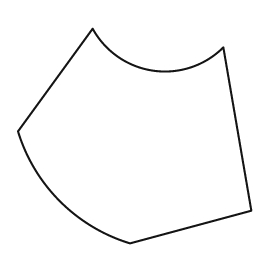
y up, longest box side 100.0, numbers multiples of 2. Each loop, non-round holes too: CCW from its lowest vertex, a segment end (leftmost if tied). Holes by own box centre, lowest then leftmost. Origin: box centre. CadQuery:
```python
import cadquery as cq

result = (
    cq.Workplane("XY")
    .moveTo(-2.0, -46.0)
    .lineTo(50.0, -32.0)
    .lineTo(38.0, 38.0)
    .threePointArc((8.0, 28.0), (-18.0, 46.0))
    .lineTo(-50.0, 2.0)
    .threePointArc((-32.0, -28.0), (-2.0, -46.0))
    .close()
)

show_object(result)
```